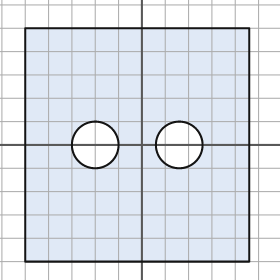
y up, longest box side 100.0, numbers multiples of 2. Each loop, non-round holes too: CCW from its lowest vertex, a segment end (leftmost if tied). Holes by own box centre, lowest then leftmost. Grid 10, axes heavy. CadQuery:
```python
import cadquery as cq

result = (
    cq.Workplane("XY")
    .moveTo(-50.0, -50.0)
    .lineTo(46.0, -50.0)
    .lineTo(46.0, 50.0)
    .lineTo(-50.0, 50.0)
    .close()
    .moveTo(-20.0, 0.0)
    .circle(10.0)
    .moveTo(16.0, 0.0)
    .circle(10.0)
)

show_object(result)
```